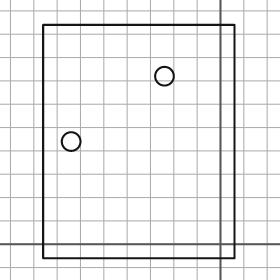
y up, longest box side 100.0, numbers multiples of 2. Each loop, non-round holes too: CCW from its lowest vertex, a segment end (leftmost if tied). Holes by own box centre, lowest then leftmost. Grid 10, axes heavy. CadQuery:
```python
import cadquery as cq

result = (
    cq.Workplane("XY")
    .moveTo(-76.0, -6.0)
    .lineTo(6.0, -6.0)
    .lineTo(6.0, 94.0)
    .lineTo(-76.0, 94.0)
    .close()
    .moveTo(-64.0, 44.0)
    .circle(4.0)
    .moveTo(-24.0, 72.0)
    .circle(4.0)
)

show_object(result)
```